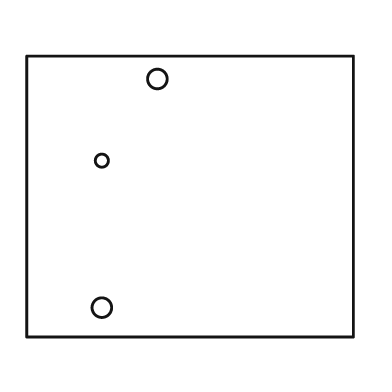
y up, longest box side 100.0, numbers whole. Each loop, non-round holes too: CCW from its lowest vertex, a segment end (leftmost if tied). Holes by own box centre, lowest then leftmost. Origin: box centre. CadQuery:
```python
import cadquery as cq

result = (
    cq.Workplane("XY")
    .moveTo(-50.0, -43.0)
    .lineTo(50.0, -43.0)
    .lineTo(50.0, 43.0)
    .lineTo(-50.0, 43.0)
    .close()
    .moveTo(-27.0, -34.0)
    .circle(3.0)
    .moveTo(-27.0, 11.0)
    .circle(2.0)
    .moveTo(-10.0, 36.0)
    .circle(3.0)
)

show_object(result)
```